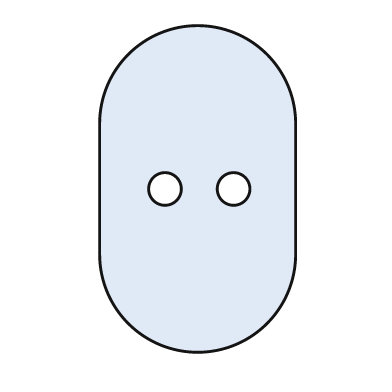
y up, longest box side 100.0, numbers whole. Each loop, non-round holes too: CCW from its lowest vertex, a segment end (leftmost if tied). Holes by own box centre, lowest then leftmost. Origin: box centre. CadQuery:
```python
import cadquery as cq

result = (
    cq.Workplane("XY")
    .moveTo(-30.0, -20.0)
    .threePointArc((0.0, -50.0), (30.0, -20.0))
    .lineTo(30.0, 20.0)
    .threePointArc((0.0, 50.0), (-30.0, 20.0))
    .close()
    .moveTo(-10.0, 0.0)
    .circle(5.0)
    .moveTo(11.0, 0.0)
    .circle(5.0)
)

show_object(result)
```